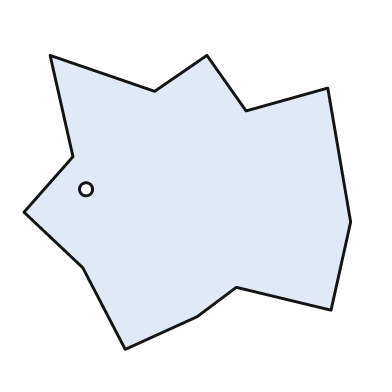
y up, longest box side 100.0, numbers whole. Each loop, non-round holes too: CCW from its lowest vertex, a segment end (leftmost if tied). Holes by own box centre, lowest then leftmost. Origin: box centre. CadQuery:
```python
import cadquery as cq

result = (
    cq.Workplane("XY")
    .moveTo(-19.0, -45.0)
    .lineTo(3.0, -35.0)
    .lineTo(15.0, -26.0)
    .lineTo(44.0, -33.0)
    .lineTo(50.0, -6.0)
    .lineTo(43.0, 35.0)
    .lineTo(18.0, 28.0)
    .lineTo(6.0, 45.0)
    .lineTo(-10.0, 34.0)
    .lineTo(-42.0, 45.0)
    .lineTo(-35.0, 14.0)
    .lineTo(-50.0, -3.0)
    .lineTo(-32.0, -20.0)
    .close()
    .moveTo(-31.0, 4.0)
    .circle(2.0)
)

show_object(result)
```